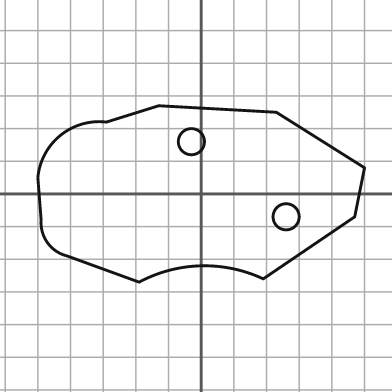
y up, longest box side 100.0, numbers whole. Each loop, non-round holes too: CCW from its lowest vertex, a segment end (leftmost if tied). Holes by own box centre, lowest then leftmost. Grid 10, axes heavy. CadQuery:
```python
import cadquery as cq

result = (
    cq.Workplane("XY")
    .moveTo(-19.0, -27.0)
    .threePointArc((0.0, -22.0), (19.0, -26.0))
    .lineTo(47.0, -7.0)
    .lineTo(50.0, 8.0)
    .lineTo(23.0, 25.0)
    .lineTo(-13.0, 27.0)
    .lineTo(-29.0, 22.0)
    .threePointArc((-43.0, 18.0), (-50.0, 5.0))
    .lineTo(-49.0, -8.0)
    .threePointArc((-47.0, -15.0), (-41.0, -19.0))
    .close()
    .moveTo(26.0, -7.0)
    .circle(4.0)
    .moveTo(-3.0, 16.0)
    .circle(4.0)
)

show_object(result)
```